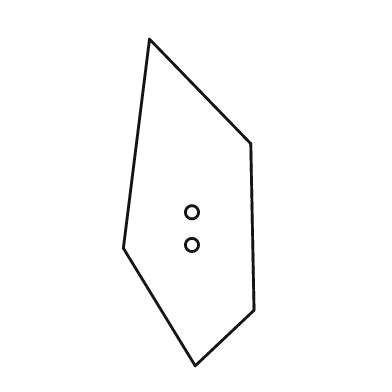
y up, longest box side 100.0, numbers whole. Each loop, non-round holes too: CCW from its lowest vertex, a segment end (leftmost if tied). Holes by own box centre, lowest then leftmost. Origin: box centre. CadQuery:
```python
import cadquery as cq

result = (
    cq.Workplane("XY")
    .moveTo(2.0, -50.0)
    .lineTo(20.0, -33.0)
    .lineTo(19.0, 18.0)
    .lineTo(-12.0, 50.0)
    .lineTo(-20.0, -14.0)
    .close()
    .moveTo(1.0, -13.0)
    .circle(2.0)
    .moveTo(1.0, -3.0)
    .circle(2.0)
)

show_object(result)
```